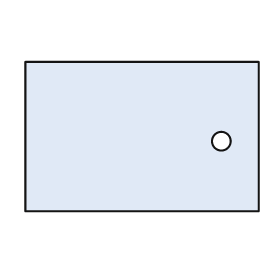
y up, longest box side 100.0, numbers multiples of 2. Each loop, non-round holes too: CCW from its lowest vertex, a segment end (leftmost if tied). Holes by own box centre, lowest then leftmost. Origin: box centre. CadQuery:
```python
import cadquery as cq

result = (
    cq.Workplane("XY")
    .moveTo(-50.0, -32.0)
    .lineTo(50.0, -32.0)
    .lineTo(50.0, 32.0)
    .lineTo(-50.0, 32.0)
    .close()
    .moveTo(34.0, -2.0)
    .circle(4.0)
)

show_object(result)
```